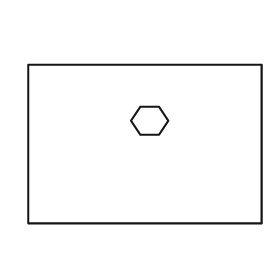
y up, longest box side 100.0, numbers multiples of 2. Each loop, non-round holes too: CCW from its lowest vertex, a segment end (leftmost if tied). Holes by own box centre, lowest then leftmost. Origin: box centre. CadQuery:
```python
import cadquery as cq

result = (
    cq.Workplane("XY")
    .moveTo(-50.0, -34.0)
    .lineTo(50.0, -34.0)
    .lineTo(50.0, 34.0)
    .lineTo(-50.0, 34.0)
    .close()
    .moveTo(-2.0, 4.0)
    .lineTo(6.0, 4.0)
    .lineTo(10.0, 10.0)
    .lineTo(6.0, 16.0)
    .lineTo(-2.0, 16.0)
    .lineTo(-6.0, 10.0)
    .close()
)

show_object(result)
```